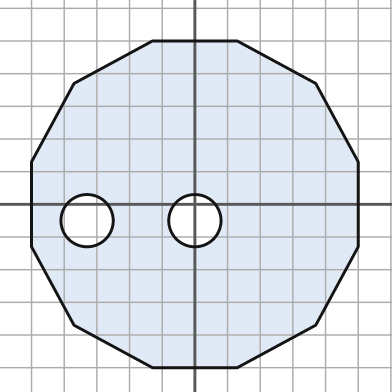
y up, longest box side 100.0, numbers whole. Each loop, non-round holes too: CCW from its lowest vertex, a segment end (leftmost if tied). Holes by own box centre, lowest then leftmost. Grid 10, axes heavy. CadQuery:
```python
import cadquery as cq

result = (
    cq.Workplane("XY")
    .moveTo(-13.0, -50.0)
    .lineTo(13.0, -50.0)
    .lineTo(37.0, -37.0)
    .lineTo(50.0, -13.0)
    .lineTo(50.0, 13.0)
    .lineTo(37.0, 37.0)
    .lineTo(13.0, 50.0)
    .lineTo(-13.0, 50.0)
    .lineTo(-37.0, 37.0)
    .lineTo(-50.0, 13.0)
    .lineTo(-50.0, -13.0)
    .lineTo(-37.0, -37.0)
    .close()
    .moveTo(-33.0, -5.0)
    .circle(8.0)
    .moveTo(0.0, -5.0)
    .circle(8.0)
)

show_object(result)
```